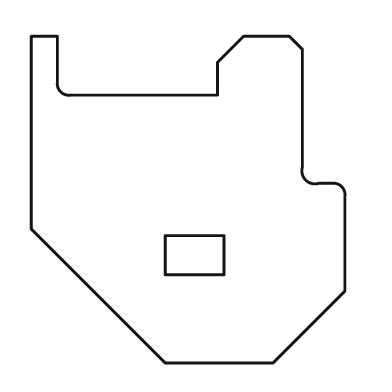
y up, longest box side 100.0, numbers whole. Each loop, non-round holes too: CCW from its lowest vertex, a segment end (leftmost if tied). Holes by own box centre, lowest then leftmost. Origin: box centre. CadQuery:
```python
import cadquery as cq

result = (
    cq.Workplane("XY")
    .moveTo(-7.0, -50.0)
    .lineTo(26.0, -50.0)
    .lineTo(48.0, -28.0)
    .lineTo(48.0, 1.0)
    .threePointArc((47.0, 4.0), (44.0, 5.0))
    .lineTo(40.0, 5.0)
    .threePointArc((36.0, 6.0), (35.0, 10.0))
    .lineTo(35.0, 46.0)
    .lineTo(31.0, 50.0)
    .lineTo(17.0, 50.0)
    .lineTo(9.0, 42.0)
    .lineTo(9.0, 32.0)
    .lineTo(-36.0, 32.0)
    .threePointArc((-39.0, 33.0), (-40.0, 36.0))
    .lineTo(-40.0, 50.0)
    .lineTo(-48.0, 50.0)
    .lineTo(-48.0, -9.0)
    .close()
    .moveTo(-7.0, -23.0)
    .lineTo(11.0, -23.0)
    .lineTo(11.0, -11.0)
    .lineTo(-7.0, -11.0)
    .close()
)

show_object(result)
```